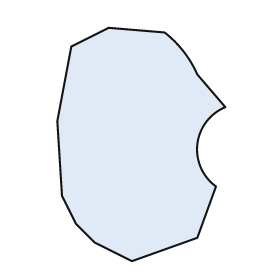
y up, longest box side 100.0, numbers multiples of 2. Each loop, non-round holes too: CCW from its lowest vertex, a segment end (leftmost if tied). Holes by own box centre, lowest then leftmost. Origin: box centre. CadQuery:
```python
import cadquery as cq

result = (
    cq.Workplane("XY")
    .moveTo(-4.0, -50.0)
    .lineTo(24.0, -40.0)
    .lineTo(32.0, -18.0)
    .threePointArc((24.0, 0.0), (36.0, 16.0))
    .lineTo(24.0, 30.0)
    .threePointArc((18.0, 40.0), (10.0, 48.0))
    .lineTo(-14.0, 50.0)
    .lineTo(-30.0, 42.0)
    .lineTo(-36.0, 10.0)
    .lineTo(-34.0, -22.0)
    .lineTo(-28.0, -34.0)
    .lineTo(-20.0, -42.0)
    .close()
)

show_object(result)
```